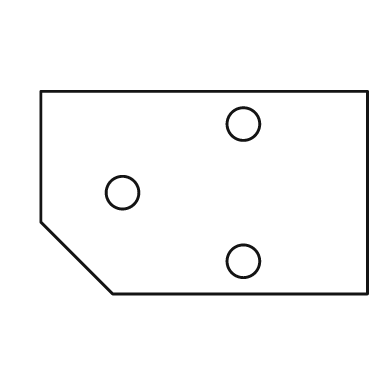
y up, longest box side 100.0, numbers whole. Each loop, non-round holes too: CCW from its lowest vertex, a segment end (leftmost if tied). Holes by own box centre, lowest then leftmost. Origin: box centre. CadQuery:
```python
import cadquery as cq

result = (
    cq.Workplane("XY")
    .moveTo(-28.0, -31.0)
    .lineTo(50.0, -31.0)
    .lineTo(50.0, 31.0)
    .lineTo(-50.0, 31.0)
    .lineTo(-50.0, -9.0)
    .close()
    .moveTo(12.0, -21.0)
    .circle(5.0)
    .moveTo(-25.0, 0.0)
    .circle(5.0)
    .moveTo(12.0, 21.0)
    .circle(5.0)
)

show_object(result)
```